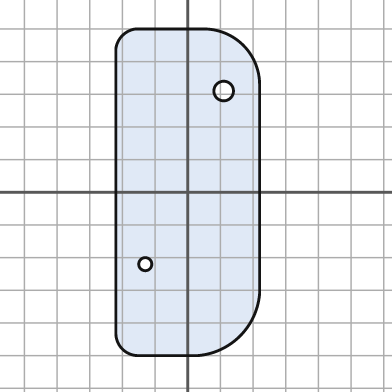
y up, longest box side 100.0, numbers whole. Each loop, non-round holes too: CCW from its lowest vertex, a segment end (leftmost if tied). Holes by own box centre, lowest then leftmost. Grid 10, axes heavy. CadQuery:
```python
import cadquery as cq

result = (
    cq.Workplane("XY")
    .moveTo(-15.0, -50.0)
    .lineTo(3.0, -50.0)
    .threePointArc((16.0, -44.0), (22.0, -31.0))
    .lineTo(22.0, 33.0)
    .threePointArc((17.0, 45.0), (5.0, 50.0))
    .lineTo(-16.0, 50.0)
    .threePointArc((-20.0, 48.0), (-22.0, 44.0))
    .lineTo(-22.0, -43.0)
    .threePointArc((-20.0, -48.0), (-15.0, -50.0))
    .close()
    .moveTo(-13.0, -22.0)
    .circle(2.0)
    .moveTo(11.0, 31.0)
    .circle(3.0)
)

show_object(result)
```